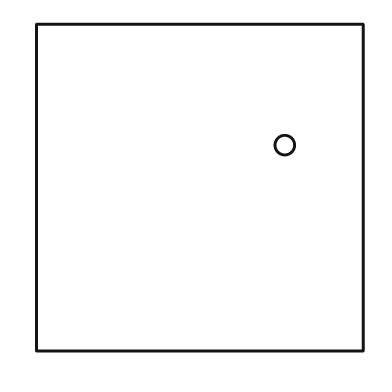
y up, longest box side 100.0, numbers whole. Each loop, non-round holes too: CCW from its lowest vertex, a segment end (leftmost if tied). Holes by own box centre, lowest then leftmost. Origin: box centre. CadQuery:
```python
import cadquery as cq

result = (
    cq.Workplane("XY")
    .moveTo(-50.0, -50.0)
    .lineTo(50.0, -50.0)
    .lineTo(50.0, 50.0)
    .lineTo(-50.0, 50.0)
    .close()
    .moveTo(26.0, 13.0)
    .circle(3.0)
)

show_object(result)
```